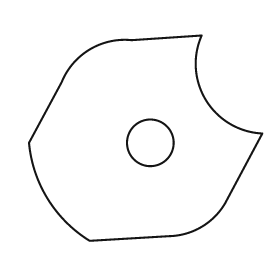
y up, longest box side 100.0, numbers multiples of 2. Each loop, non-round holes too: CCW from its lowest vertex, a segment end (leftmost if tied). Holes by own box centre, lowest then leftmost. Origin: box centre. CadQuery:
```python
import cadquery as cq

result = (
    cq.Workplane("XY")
    .moveTo(-24.0, -44.0)
    .lineTo(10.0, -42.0)
    .threePointArc((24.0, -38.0), (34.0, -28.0))
    .lineTo(50.0, 2.0)
    .threePointArc((26.0, 16.0), (24.0, 44.0))
    .lineTo(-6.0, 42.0)
    .threePointArc((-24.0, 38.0), (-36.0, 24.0))
    .lineTo(-50.0, -2.0)
    .threePointArc((-42.0, -26.0), (-24.0, -44.0))
    .close()
    .moveTo(2.0, -2.0)
    .circle(10.0)
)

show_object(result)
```